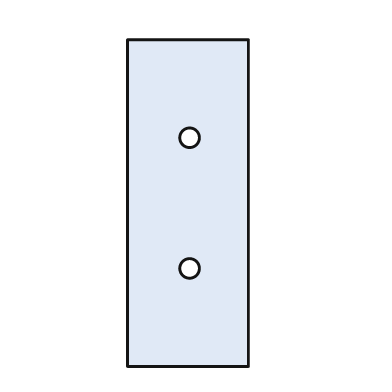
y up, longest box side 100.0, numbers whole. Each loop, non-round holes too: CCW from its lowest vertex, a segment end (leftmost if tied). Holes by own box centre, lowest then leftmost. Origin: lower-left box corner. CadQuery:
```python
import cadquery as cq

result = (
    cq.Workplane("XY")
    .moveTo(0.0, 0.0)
    .lineTo(37.0, 0.0)
    .lineTo(37.0, 100.0)
    .lineTo(0.0, 100.0)
    .close()
    .moveTo(19.0, 30.0)
    .circle(3.0)
    .moveTo(19.0, 70.0)
    .circle(3.0)
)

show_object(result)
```